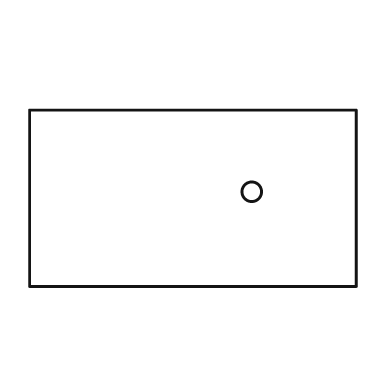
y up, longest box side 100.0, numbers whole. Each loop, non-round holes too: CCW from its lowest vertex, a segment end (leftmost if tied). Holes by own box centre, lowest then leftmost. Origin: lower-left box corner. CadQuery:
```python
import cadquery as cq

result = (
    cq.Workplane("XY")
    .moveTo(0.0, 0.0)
    .lineTo(100.0, 0.0)
    .lineTo(100.0, 54.0)
    .lineTo(0.0, 54.0)
    .close()
    .moveTo(68.0, 29.0)
    .circle(3.0)
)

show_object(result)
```